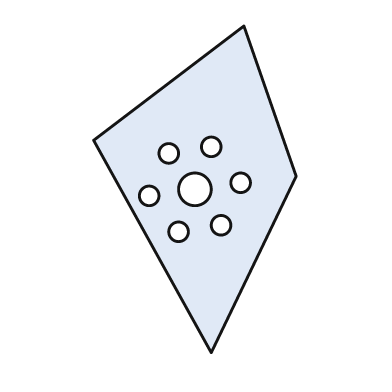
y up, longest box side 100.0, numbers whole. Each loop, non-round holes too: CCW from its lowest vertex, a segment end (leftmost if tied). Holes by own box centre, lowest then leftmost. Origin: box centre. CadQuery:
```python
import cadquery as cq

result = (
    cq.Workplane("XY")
    .moveTo(5.0, -50.0)
    .lineTo(31.0, 4.0)
    .lineTo(15.0, 50.0)
    .lineTo(-31.0, 15.0)
    .close()
    .moveTo(-5.0, -13.0)
    .circle(3.0)
    .moveTo(8.0, -11.0)
    .circle(3.0)
    .moveTo(-14.0, -2.0)
    .circle(3.0)
    .moveTo(0.0, 0.0)
    .circle(5.0)
    .moveTo(14.0, 2.0)
    .circle(3.0)
    .moveTo(-8.0, 11.0)
    .circle(3.0)
    .moveTo(5.0, 13.0)
    .circle(3.0)
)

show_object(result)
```